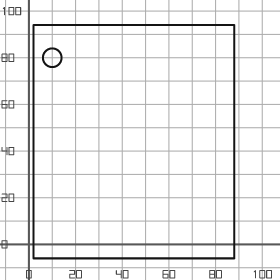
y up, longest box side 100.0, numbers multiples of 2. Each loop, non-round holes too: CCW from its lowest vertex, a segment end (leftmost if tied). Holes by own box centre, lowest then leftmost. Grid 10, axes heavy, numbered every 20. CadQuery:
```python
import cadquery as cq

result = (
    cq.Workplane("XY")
    .moveTo(2.0, -6.0)
    .lineTo(88.0, -6.0)
    .lineTo(88.0, 94.0)
    .lineTo(2.0, 94.0)
    .close()
    .moveTo(10.0, 80.0)
    .circle(4.0)
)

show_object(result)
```